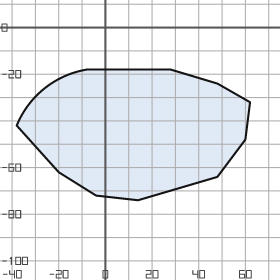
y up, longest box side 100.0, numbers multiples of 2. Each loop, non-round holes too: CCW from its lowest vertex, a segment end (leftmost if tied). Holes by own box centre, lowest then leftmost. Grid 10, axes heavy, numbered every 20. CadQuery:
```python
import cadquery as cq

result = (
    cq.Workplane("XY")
    .moveTo(14.0, -74.0)
    .lineTo(48.0, -64.0)
    .lineTo(60.0, -48.0)
    .lineTo(62.0, -32.0)
    .lineTo(48.0, -24.0)
    .lineTo(28.0, -18.0)
    .lineTo(-8.0, -18.0)
    .threePointArc((-26.0, -26.0), (-38.0, -42.0))
    .lineTo(-20.0, -62.0)
    .lineTo(-4.0, -72.0)
    .close()
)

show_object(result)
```